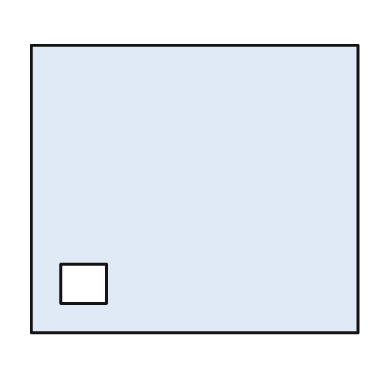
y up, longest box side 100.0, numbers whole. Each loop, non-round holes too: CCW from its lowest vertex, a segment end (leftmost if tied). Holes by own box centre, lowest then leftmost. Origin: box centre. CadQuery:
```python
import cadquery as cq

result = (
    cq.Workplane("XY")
    .moveTo(-50.0, -44.0)
    .lineTo(50.0, -44.0)
    .lineTo(50.0, 44.0)
    .lineTo(-50.0, 44.0)
    .close()
    .moveTo(-41.0, -35.0)
    .lineTo(-27.0, -35.0)
    .lineTo(-27.0, -23.0)
    .lineTo(-41.0, -23.0)
    .close()
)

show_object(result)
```